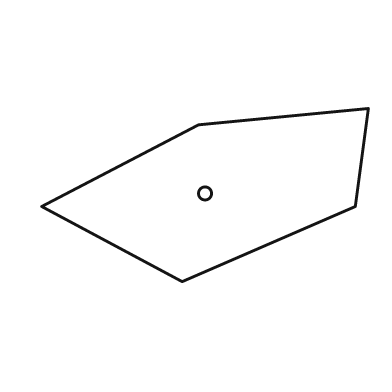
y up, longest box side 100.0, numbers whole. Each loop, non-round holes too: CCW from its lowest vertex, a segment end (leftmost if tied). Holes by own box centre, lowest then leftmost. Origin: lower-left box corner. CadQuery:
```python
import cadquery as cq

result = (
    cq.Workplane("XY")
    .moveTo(43.0, 0.0)
    .lineTo(96.0, 23.0)
    .lineTo(100.0, 53.0)
    .lineTo(48.0, 48.0)
    .lineTo(0.0, 23.0)
    .close()
    .moveTo(50.0, 27.0)
    .circle(2.0)
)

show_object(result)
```